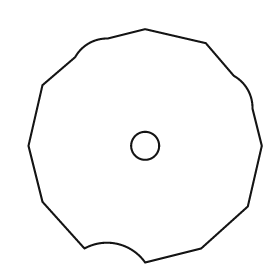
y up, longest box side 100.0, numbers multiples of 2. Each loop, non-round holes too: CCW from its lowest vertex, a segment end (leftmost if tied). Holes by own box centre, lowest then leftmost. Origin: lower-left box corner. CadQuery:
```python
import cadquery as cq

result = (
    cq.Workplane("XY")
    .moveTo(50.0, 0.0)
    .lineTo(74.0, 6.0)
    .lineTo(94.0, 24.0)
    .lineTo(100.0, 50.0)
    .lineTo(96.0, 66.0)
    .threePointArc((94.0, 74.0), (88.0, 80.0))
    .lineTo(76.0, 94.0)
    .lineTo(50.0, 100.0)
    .lineTo(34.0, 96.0)
    .threePointArc((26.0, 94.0), (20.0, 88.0))
    .lineTo(6.0, 76.0)
    .lineTo(0.0, 50.0)
    .lineTo(6.0, 26.0)
    .lineTo(24.0, 6.0)
    .threePointArc((38.0, 8.0), (50.0, 0.0))
    .close()
    .moveTo(50.0, 50.0)
    .circle(6.0)
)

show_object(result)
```